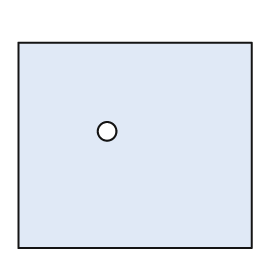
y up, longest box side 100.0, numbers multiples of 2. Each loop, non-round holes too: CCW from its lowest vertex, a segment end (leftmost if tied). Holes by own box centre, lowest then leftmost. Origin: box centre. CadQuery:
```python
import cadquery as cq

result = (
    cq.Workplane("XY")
    .moveTo(-50.0, -44.0)
    .lineTo(50.0, -44.0)
    .lineTo(50.0, 44.0)
    .lineTo(-50.0, 44.0)
    .close()
    .moveTo(-12.0, 6.0)
    .circle(4.0)
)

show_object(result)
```